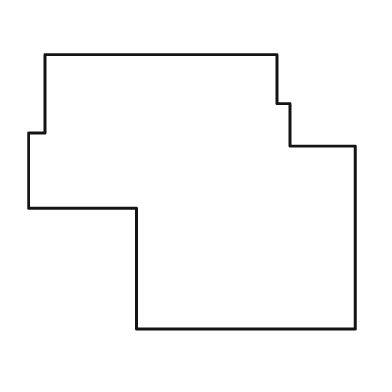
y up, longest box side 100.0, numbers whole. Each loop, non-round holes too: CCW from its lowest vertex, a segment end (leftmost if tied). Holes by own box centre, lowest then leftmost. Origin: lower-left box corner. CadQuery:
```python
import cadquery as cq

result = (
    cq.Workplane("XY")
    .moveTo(33.0, 0.0)
    .lineTo(100.0, 0.0)
    .lineTo(100.0, 56.0)
    .lineTo(80.0, 56.0)
    .lineTo(80.0, 69.0)
    .lineTo(76.0, 69.0)
    .lineTo(76.0, 84.0)
    .lineTo(5.0, 84.0)
    .lineTo(5.0, 60.0)
    .lineTo(0.0, 60.0)
    .lineTo(0.0, 37.0)
    .lineTo(33.0, 37.0)
    .close()
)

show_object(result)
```